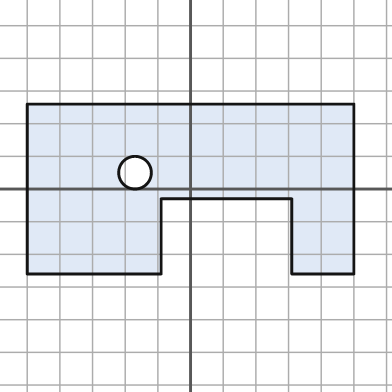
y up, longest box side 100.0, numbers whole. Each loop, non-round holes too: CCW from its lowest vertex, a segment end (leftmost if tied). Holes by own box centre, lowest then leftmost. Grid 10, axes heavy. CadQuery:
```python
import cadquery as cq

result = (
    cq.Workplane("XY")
    .moveTo(-50.0, -26.0)
    .lineTo(-9.0, -26.0)
    .lineTo(-9.0, -3.0)
    .lineTo(31.0, -3.0)
    .lineTo(31.0, -26.0)
    .lineTo(50.0, -26.0)
    .lineTo(50.0, 26.0)
    .lineTo(-50.0, 26.0)
    .close()
    .moveTo(-17.0, 5.0)
    .circle(5.0)
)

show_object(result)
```